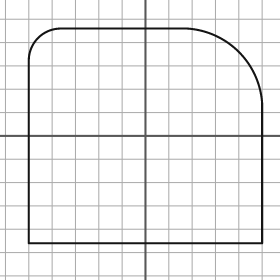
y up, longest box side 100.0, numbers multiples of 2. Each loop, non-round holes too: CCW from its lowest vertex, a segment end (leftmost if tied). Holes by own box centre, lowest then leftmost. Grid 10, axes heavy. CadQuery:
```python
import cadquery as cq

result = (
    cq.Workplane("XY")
    .moveTo(-50.0, -46.0)
    .lineTo(50.0, -46.0)
    .lineTo(50.0, 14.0)
    .threePointArc((40.0, 36.0), (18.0, 46.0))
    .lineTo(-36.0, 46.0)
    .threePointArc((-46.0, 42.0), (-50.0, 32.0))
    .close()
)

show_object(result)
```